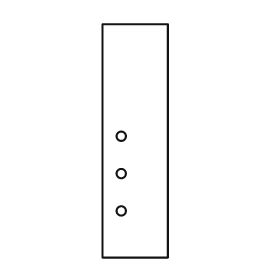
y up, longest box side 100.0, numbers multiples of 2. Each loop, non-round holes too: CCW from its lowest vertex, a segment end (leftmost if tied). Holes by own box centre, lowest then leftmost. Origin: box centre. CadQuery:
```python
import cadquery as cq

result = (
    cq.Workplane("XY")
    .moveTo(-14.0, -50.0)
    .lineTo(14.0, -50.0)
    .lineTo(14.0, 50.0)
    .lineTo(-14.0, 50.0)
    .close()
    .moveTo(-6.0, -30.0)
    .circle(2.0)
    .moveTo(-6.0, -14.0)
    .circle(2.0)
    .moveTo(-6.0, 2.0)
    .circle(2.0)
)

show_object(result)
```